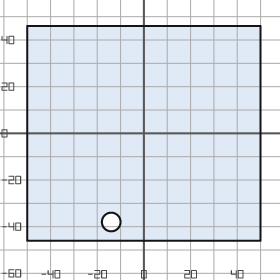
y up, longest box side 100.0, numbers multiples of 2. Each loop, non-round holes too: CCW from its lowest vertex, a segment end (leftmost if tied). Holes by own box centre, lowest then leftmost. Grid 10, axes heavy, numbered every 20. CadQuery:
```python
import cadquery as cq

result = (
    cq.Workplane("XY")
    .moveTo(-50.0, -46.0)
    .lineTo(50.0, -46.0)
    .lineTo(50.0, 46.0)
    .lineTo(-50.0, 46.0)
    .close()
    .moveTo(-14.0, -38.0)
    .circle(4.0)
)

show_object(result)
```